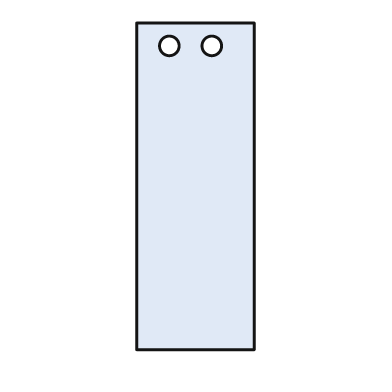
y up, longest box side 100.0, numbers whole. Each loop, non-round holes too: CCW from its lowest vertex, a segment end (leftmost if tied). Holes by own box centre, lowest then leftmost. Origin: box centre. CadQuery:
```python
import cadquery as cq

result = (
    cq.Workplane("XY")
    .moveTo(-18.0, -50.0)
    .lineTo(18.0, -50.0)
    .lineTo(18.0, 50.0)
    .lineTo(-18.0, 50.0)
    .close()
    .moveTo(-8.0, 43.0)
    .circle(3.0)
    .moveTo(5.0, 43.0)
    .circle(3.0)
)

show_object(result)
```